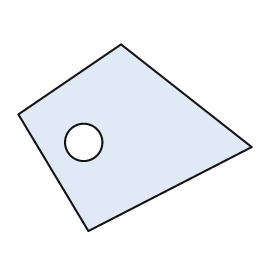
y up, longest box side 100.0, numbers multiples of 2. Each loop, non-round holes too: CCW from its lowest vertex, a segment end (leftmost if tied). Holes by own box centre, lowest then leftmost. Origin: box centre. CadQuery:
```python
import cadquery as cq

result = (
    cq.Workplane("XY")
    .moveTo(-20.0, -40.0)
    .lineTo(50.0, -4.0)
    .lineTo(-6.0, 40.0)
    .lineTo(-50.0, 10.0)
    .close()
    .moveTo(-22.0, -2.0)
    .circle(8.0)
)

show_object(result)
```